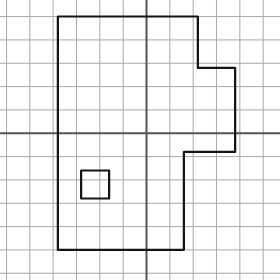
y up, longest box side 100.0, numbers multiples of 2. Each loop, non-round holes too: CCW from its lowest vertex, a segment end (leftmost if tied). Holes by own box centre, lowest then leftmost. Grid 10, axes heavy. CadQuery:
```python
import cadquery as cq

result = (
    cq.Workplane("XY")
    .moveTo(-38.0, -50.0)
    .lineTo(16.0, -50.0)
    .lineTo(16.0, -8.0)
    .lineTo(38.0, -8.0)
    .lineTo(38.0, 28.0)
    .lineTo(22.0, 28.0)
    .lineTo(22.0, 50.0)
    .lineTo(-38.0, 50.0)
    .close()
    .moveTo(-28.0, -28.0)
    .lineTo(-16.0, -28.0)
    .lineTo(-16.0, -16.0)
    .lineTo(-28.0, -16.0)
    .close()
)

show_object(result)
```